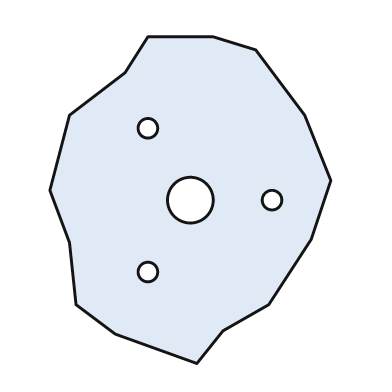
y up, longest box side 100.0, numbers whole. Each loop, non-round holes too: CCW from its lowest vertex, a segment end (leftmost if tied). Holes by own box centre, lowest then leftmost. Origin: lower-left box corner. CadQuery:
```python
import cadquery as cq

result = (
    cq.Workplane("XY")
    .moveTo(45.0, 0.0)
    .lineTo(53.0, 10.0)
    .lineTo(67.0, 18.0)
    .lineTo(80.0, 38.0)
    .lineTo(86.0, 56.0)
    .lineTo(78.0, 76.0)
    .lineTo(63.0, 96.0)
    .lineTo(50.0, 100.0)
    .lineTo(30.0, 100.0)
    .lineTo(23.0, 89.0)
    .lineTo(6.0, 76.0)
    .lineTo(0.0, 53.0)
    .lineTo(6.0, 37.0)
    .lineTo(8.0, 18.0)
    .lineTo(20.0, 9.0)
    .close()
    .moveTo(30.0, 28.0)
    .circle(3.0)
    .moveTo(43.0, 50.0)
    .circle(7.0)
    .moveTo(68.0, 50.0)
    .circle(3.0)
    .moveTo(30.0, 72.0)
    .circle(3.0)
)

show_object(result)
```